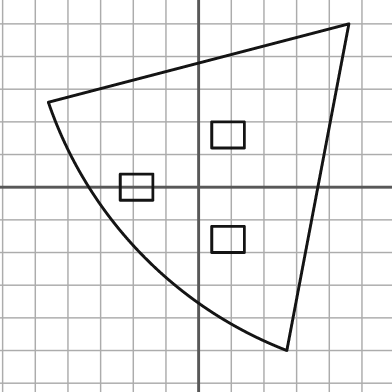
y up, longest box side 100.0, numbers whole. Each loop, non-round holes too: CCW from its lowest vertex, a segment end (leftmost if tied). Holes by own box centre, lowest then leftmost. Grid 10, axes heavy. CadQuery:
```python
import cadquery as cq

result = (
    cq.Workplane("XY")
    .moveTo(27.0, -50.0)
    .lineTo(46.0, 50.0)
    .lineTo(-46.0, 26.0)
    .threePointArc((-18.0, -20.0), (27.0, -50.0))
    .close()
    .moveTo(4.0, -20.0)
    .lineTo(14.0, -20.0)
    .lineTo(14.0, -12.0)
    .lineTo(4.0, -12.0)
    .close()
    .moveTo(-24.0, -4.0)
    .lineTo(-14.0, -4.0)
    .lineTo(-14.0, 4.0)
    .lineTo(-24.0, 4.0)
    .close()
    .moveTo(4.0, 12.0)
    .lineTo(14.0, 12.0)
    .lineTo(14.0, 20.0)
    .lineTo(4.0, 20.0)
    .close()
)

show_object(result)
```